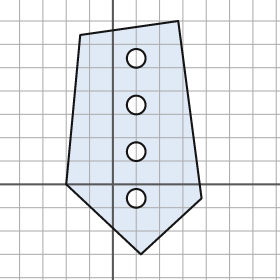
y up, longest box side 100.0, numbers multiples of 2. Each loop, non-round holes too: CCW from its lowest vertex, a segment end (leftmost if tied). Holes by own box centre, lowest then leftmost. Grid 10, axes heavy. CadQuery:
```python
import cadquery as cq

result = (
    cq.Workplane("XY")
    .moveTo(12.0, -30.0)
    .lineTo(38.0, -6.0)
    .lineTo(28.0, 70.0)
    .lineTo(-14.0, 64.0)
    .lineTo(-20.0, 0.0)
    .close()
    .moveTo(10.0, -6.0)
    .circle(4.0)
    .moveTo(10.0, 14.0)
    .circle(4.0)
    .moveTo(10.0, 34.0)
    .circle(4.0)
    .moveTo(10.0, 54.0)
    .circle(4.0)
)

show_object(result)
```